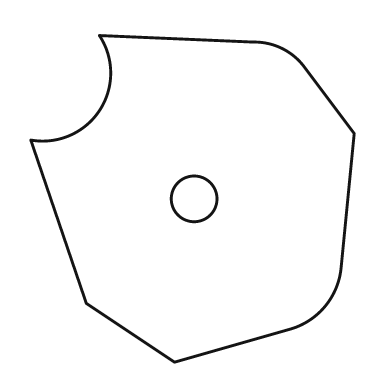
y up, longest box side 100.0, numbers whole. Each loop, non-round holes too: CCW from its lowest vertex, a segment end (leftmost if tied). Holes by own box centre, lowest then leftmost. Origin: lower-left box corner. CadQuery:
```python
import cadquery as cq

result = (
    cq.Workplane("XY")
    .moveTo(44.0, 0.0)
    .lineTo(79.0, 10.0)
    .threePointArc((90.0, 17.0), (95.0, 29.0))
    .lineTo(99.0, 70.0)
    .lineTo(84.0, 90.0)
    .threePointArc((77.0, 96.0), (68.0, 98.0))
    .lineTo(21.0, 100.0)
    .threePointArc((21.0, 77.0), (0.0, 68.0))
    .lineTo(17.0, 18.0)
    .close()
    .moveTo(50.0, 50.0)
    .circle(7.0)
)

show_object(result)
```